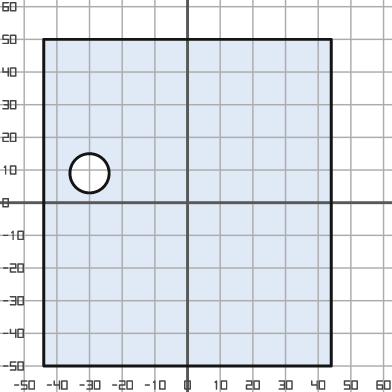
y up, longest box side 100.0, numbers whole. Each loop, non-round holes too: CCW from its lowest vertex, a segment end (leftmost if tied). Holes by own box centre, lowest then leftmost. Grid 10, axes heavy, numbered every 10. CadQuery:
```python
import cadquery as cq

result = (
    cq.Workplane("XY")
    .moveTo(-44.0, -50.0)
    .lineTo(44.0, -50.0)
    .lineTo(44.0, 50.0)
    .lineTo(-44.0, 50.0)
    .close()
    .moveTo(-30.0, 9.0)
    .circle(6.0)
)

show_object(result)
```